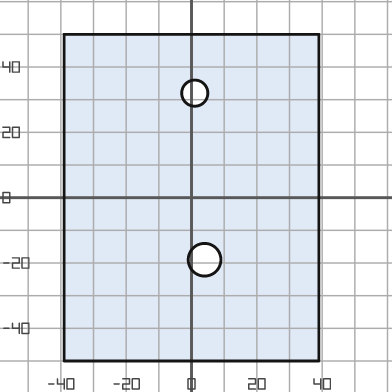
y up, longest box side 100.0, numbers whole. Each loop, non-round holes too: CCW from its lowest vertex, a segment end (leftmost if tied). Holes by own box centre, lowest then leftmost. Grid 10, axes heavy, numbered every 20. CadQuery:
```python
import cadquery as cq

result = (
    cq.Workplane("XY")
    .moveTo(-39.0, -50.0)
    .lineTo(39.0, -50.0)
    .lineTo(39.0, 50.0)
    .lineTo(-39.0, 50.0)
    .close()
    .moveTo(4.0, -19.0)
    .circle(5.0)
    .moveTo(1.0, 32.0)
    .circle(4.0)
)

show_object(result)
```